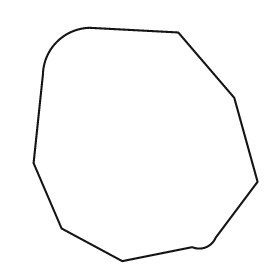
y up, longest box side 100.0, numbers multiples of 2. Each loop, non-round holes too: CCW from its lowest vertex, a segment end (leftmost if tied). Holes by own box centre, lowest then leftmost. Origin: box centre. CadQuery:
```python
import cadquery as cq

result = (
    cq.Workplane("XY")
    .moveTo(-10.0, -50.0)
    .lineTo(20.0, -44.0)
    .threePointArc((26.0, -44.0), (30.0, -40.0))
    .lineTo(48.0, -16.0)
    .lineTo(38.0, 20.0)
    .lineTo(14.0, 48.0)
    .lineTo(-24.0, 50.0)
    .threePointArc((-38.0, 44.0), (-44.0, 30.0))
    .lineTo(-48.0, -8.0)
    .lineTo(-36.0, -36.0)
    .close()
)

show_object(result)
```